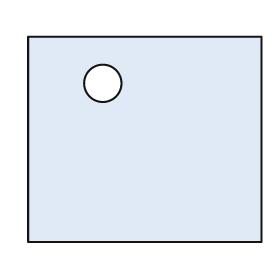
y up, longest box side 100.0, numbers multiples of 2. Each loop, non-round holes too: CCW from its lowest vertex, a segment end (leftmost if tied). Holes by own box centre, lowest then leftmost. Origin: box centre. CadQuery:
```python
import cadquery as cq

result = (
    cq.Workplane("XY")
    .moveTo(-50.0, -44.0)
    .lineTo(50.0, -44.0)
    .lineTo(50.0, 44.0)
    .lineTo(-50.0, 44.0)
    .close()
    .moveTo(-18.0, 24.0)
    .circle(8.0)
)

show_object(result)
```